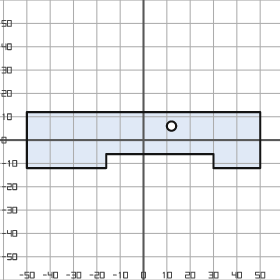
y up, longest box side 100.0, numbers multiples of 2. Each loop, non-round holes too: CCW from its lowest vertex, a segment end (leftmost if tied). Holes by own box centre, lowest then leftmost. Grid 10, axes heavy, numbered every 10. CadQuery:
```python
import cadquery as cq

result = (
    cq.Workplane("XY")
    .moveTo(-50.0, -12.0)
    .lineTo(-16.0, -12.0)
    .lineTo(-16.0, -6.0)
    .lineTo(30.0, -6.0)
    .lineTo(30.0, -12.0)
    .lineTo(50.0, -12.0)
    .lineTo(50.0, 12.0)
    .lineTo(-50.0, 12.0)
    .close()
    .moveTo(12.0, 6.0)
    .circle(2.0)
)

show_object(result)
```